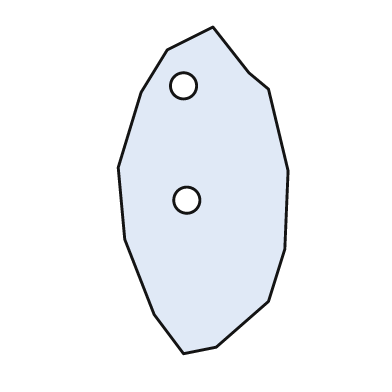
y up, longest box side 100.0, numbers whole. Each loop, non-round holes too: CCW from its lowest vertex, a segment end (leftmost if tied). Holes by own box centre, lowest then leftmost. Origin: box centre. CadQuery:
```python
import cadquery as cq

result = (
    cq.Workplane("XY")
    .moveTo(-6.0, -50.0)
    .lineTo(4.0, -48.0)
    .lineTo(20.0, -34.0)
    .lineTo(25.0, -18.0)
    .lineTo(26.0, 6.0)
    .lineTo(20.0, 31.0)
    .lineTo(14.0, 36.0)
    .lineTo(3.0, 50.0)
    .lineTo(-11.0, 43.0)
    .lineTo(-19.0, 30.0)
    .lineTo(-26.0, 7.0)
    .lineTo(-24.0, -15.0)
    .lineTo(-15.0, -38.0)
    .close()
    .moveTo(-5.0, -3.0)
    .circle(4.0)
    .moveTo(-6.0, 32.0)
    .circle(4.0)
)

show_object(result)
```